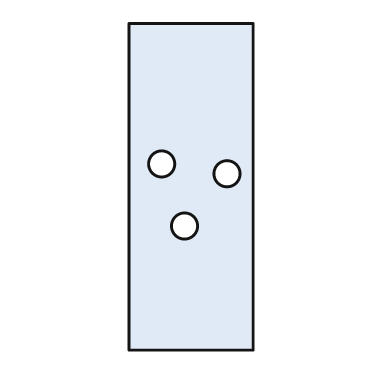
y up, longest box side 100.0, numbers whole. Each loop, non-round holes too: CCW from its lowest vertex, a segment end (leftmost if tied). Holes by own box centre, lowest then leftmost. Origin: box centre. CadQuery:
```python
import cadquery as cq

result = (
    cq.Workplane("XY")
    .moveTo(-19.0, -50.0)
    .lineTo(19.0, -50.0)
    .lineTo(19.0, 50.0)
    .lineTo(-19.0, 50.0)
    .close()
    .moveTo(-2.0, -12.0)
    .circle(4.0)
    .moveTo(11.0, 4.0)
    .circle(4.0)
    .moveTo(-9.0, 7.0)
    .circle(4.0)
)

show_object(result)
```